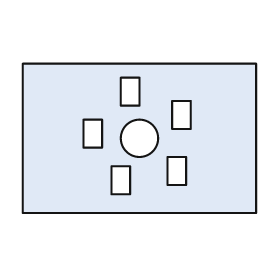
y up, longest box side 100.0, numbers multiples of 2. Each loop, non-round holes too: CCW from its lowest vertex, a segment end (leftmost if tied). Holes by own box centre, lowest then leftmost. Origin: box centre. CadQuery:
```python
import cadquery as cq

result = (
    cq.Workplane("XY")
    .moveTo(-50.0, -32.0)
    .lineTo(50.0, -32.0)
    .lineTo(50.0, 32.0)
    .lineTo(-50.0, 32.0)
    .close()
    .moveTo(-12.0, -24.0)
    .lineTo(-4.0, -24.0)
    .lineTo(-4.0, -12.0)
    .lineTo(-12.0, -12.0)
    .close()
    .moveTo(12.0, -20.0)
    .lineTo(20.0, -20.0)
    .lineTo(20.0, -8.0)
    .lineTo(12.0, -8.0)
    .close()
    .moveTo(0.0, 0.0)
    .circle(8.0)
    .moveTo(-24.0, -4.0)
    .lineTo(-16.0, -4.0)
    .lineTo(-16.0, 8.0)
    .lineTo(-24.0, 8.0)
    .close()
    .moveTo(14.0, 4.0)
    .lineTo(22.0, 4.0)
    .lineTo(22.0, 16.0)
    .lineTo(14.0, 16.0)
    .close()
    .moveTo(-8.0, 14.0)
    .lineTo(0.0, 14.0)
    .lineTo(0.0, 26.0)
    .lineTo(-8.0, 26.0)
    .close()
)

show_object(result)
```